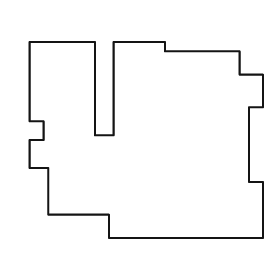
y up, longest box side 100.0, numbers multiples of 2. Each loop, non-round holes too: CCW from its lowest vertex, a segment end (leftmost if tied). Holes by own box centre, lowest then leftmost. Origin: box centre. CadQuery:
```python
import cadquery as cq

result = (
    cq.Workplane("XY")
    .moveTo(-16.0, -42.0)
    .lineTo(50.0, -42.0)
    .lineTo(50.0, -18.0)
    .lineTo(44.0, -18.0)
    .lineTo(44.0, 14.0)
    .lineTo(50.0, 14.0)
    .lineTo(50.0, 28.0)
    .lineTo(40.0, 28.0)
    .lineTo(40.0, 38.0)
    .lineTo(8.0, 38.0)
    .lineTo(8.0, 42.0)
    .lineTo(-14.0, 42.0)
    .lineTo(-14.0, 2.0)
    .lineTo(-22.0, 2.0)
    .lineTo(-22.0, 42.0)
    .lineTo(-50.0, 42.0)
    .lineTo(-50.0, 8.0)
    .lineTo(-44.0, 8.0)
    .lineTo(-44.0, 0.0)
    .lineTo(-50.0, 0.0)
    .lineTo(-50.0, -12.0)
    .lineTo(-42.0, -12.0)
    .lineTo(-42.0, -32.0)
    .lineTo(-16.0, -32.0)
    .close()
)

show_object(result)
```